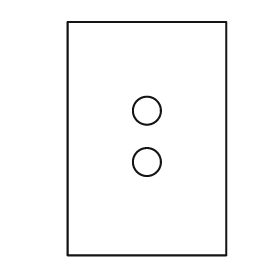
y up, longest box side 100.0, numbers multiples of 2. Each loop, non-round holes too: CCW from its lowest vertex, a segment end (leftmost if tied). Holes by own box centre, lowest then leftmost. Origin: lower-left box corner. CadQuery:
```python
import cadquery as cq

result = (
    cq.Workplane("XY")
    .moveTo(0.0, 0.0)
    .lineTo(68.0, 0.0)
    .lineTo(68.0, 100.0)
    .lineTo(0.0, 100.0)
    .close()
    .moveTo(34.0, 40.0)
    .circle(6.0)
    .moveTo(34.0, 62.0)
    .circle(6.0)
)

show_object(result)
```